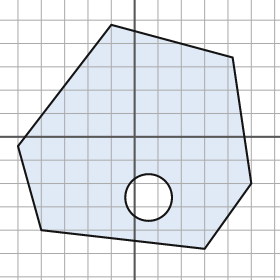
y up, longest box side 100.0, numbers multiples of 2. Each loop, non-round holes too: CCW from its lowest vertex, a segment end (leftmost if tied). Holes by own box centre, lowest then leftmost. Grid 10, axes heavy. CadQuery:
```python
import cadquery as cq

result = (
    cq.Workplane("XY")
    .moveTo(30.0, -48.0)
    .lineTo(50.0, -20.0)
    .lineTo(42.0, 34.0)
    .lineTo(-10.0, 48.0)
    .lineTo(-50.0, -4.0)
    .lineTo(-40.0, -40.0)
    .close()
    .moveTo(6.0, -26.0)
    .circle(10.0)
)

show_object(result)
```